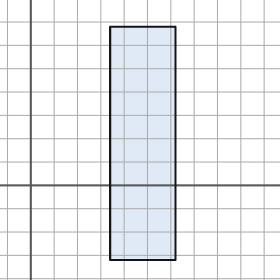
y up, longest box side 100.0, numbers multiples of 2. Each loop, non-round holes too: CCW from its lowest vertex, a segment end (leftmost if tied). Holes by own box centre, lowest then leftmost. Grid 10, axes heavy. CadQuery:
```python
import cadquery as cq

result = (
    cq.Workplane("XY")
    .moveTo(34.0, -32.0)
    .lineTo(62.0, -32.0)
    .lineTo(62.0, 68.0)
    .lineTo(34.0, 68.0)
    .close()
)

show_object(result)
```